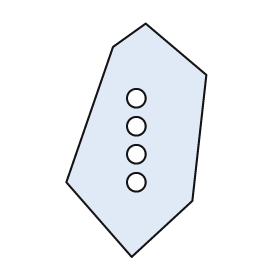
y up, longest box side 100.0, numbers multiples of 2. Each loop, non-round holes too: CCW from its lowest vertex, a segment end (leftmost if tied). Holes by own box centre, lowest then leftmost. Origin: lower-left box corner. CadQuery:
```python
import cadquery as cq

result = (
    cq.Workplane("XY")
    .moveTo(28.0, 0.0)
    .lineTo(54.0, 24.0)
    .lineTo(60.0, 78.0)
    .lineTo(34.0, 100.0)
    .lineTo(20.0, 90.0)
    .lineTo(0.0, 32.0)
    .close()
    .moveTo(30.0, 32.0)
    .circle(4.0)
    .moveTo(30.0, 44.0)
    .circle(4.0)
    .moveTo(30.0, 56.0)
    .circle(4.0)
    .moveTo(30.0, 68.0)
    .circle(4.0)
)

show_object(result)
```